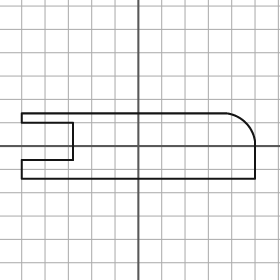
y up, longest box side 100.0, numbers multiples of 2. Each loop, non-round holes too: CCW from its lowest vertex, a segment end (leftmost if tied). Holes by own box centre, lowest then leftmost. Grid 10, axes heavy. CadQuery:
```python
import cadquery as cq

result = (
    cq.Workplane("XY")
    .moveTo(-50.0, -14.0)
    .lineTo(50.0, -14.0)
    .lineTo(50.0, 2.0)
    .threePointArc((46.0, 10.0), (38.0, 14.0))
    .lineTo(-50.0, 14.0)
    .lineTo(-50.0, 10.0)
    .lineTo(-28.0, 10.0)
    .lineTo(-28.0, -6.0)
    .lineTo(-50.0, -6.0)
    .close()
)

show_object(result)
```